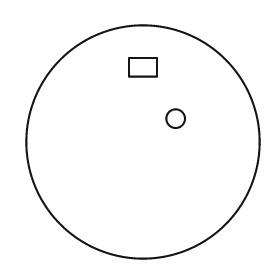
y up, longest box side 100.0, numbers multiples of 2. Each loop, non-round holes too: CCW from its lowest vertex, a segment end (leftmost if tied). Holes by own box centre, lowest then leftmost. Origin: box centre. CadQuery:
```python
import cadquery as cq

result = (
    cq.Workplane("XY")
    .moveTo(0.0, 0.0)
    .circle(50.0)
    .moveTo(14.0, 10.0)
    .circle(4.0)
    .moveTo(-6.0, 28.0)
    .lineTo(6.0, 28.0)
    .lineTo(6.0, 36.0)
    .lineTo(-6.0, 36.0)
    .close()
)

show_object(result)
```